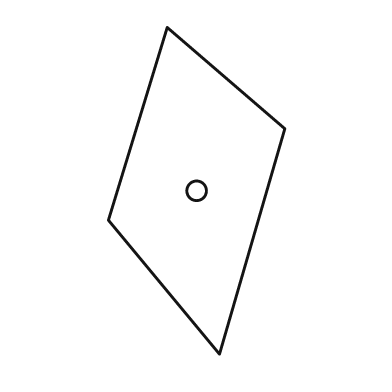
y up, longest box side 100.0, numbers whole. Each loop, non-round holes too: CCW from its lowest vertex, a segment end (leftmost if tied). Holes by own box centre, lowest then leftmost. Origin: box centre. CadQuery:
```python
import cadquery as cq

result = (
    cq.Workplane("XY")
    .moveTo(7.0, -50.0)
    .lineTo(27.0, 19.0)
    .lineTo(-9.0, 50.0)
    .lineTo(-27.0, -9.0)
    .close()
    .moveTo(0.0, 0.0)
    .circle(3.0)
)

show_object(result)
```